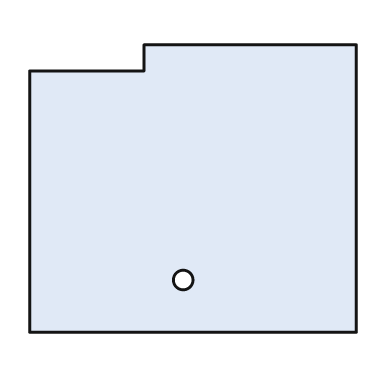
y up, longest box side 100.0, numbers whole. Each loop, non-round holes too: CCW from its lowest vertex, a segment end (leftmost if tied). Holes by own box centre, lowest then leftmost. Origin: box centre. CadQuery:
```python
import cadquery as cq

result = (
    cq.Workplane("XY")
    .moveTo(-50.0, -44.0)
    .lineTo(50.0, -44.0)
    .lineTo(50.0, 44.0)
    .lineTo(-15.0, 44.0)
    .lineTo(-15.0, 36.0)
    .lineTo(-50.0, 36.0)
    .close()
    .moveTo(-3.0, -28.0)
    .circle(3.0)
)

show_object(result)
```